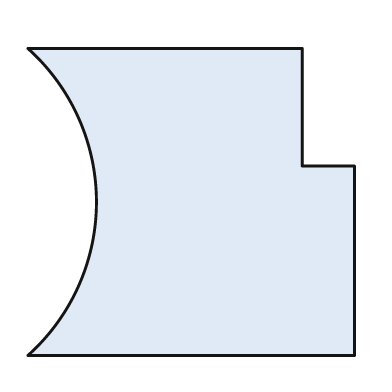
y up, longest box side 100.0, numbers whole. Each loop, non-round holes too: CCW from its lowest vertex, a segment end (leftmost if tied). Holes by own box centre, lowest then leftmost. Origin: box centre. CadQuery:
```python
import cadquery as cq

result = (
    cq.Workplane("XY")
    .moveTo(-50.0, -47.0)
    .lineTo(50.0, -47.0)
    .lineTo(50.0, 11.0)
    .lineTo(34.0, 11.0)
    .lineTo(34.0, 47.0)
    .lineTo(-50.0, 47.0)
    .threePointArc((-29.0, 0.0), (-50.0, -47.0))
    .close()
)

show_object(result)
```